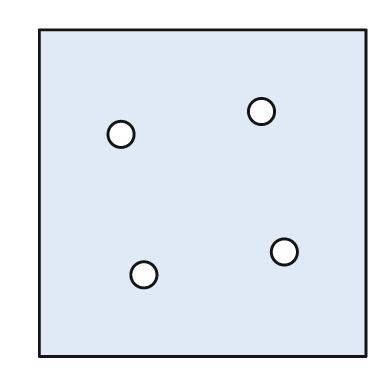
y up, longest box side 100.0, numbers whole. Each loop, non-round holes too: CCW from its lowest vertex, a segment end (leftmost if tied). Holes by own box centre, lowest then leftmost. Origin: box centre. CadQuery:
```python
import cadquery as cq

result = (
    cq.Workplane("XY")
    .moveTo(-50.0, -50.0)
    .lineTo(50.0, -50.0)
    .lineTo(50.0, 50.0)
    .lineTo(-50.0, 50.0)
    .close()
    .moveTo(-18.0, -25.0)
    .circle(4.0)
    .moveTo(25.0, -18.0)
    .circle(4.0)
    .moveTo(-25.0, 18.0)
    .circle(4.0)
    .moveTo(18.0, 25.0)
    .circle(4.0)
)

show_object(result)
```